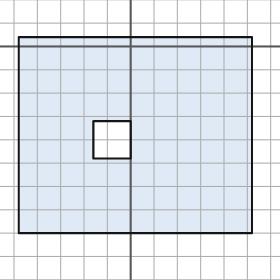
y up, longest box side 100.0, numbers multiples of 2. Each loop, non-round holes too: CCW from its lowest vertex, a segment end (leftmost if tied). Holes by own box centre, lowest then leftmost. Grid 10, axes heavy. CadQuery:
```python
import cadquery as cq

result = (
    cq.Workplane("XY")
    .moveTo(-48.0, -80.0)
    .lineTo(52.0, -80.0)
    .lineTo(52.0, 4.0)
    .lineTo(-48.0, 4.0)
    .close()
    .moveTo(-16.0, -48.0)
    .lineTo(0.0, -48.0)
    .lineTo(0.0, -32.0)
    .lineTo(-16.0, -32.0)
    .close()
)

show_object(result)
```